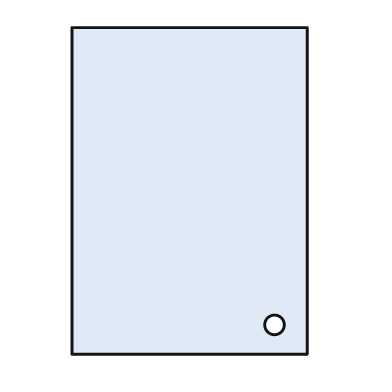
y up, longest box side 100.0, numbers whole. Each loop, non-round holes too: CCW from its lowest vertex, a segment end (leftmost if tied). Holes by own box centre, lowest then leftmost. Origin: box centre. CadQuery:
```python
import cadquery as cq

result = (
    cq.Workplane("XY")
    .moveTo(-36.0, -50.0)
    .lineTo(36.0, -50.0)
    .lineTo(36.0, 50.0)
    .lineTo(-36.0, 50.0)
    .close()
    .moveTo(26.0, -41.0)
    .circle(3.0)
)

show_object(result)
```